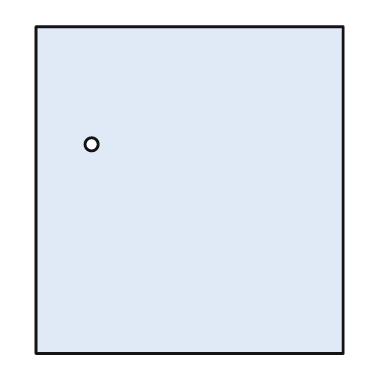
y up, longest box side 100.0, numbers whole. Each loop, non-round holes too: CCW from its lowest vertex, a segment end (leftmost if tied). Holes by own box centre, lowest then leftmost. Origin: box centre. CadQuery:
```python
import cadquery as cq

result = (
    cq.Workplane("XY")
    .moveTo(-47.0, -50.0)
    .lineTo(47.0, -50.0)
    .lineTo(47.0, 50.0)
    .lineTo(-47.0, 50.0)
    .close()
    .moveTo(-30.0, 14.0)
    .circle(2.0)
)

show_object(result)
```